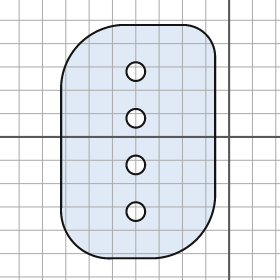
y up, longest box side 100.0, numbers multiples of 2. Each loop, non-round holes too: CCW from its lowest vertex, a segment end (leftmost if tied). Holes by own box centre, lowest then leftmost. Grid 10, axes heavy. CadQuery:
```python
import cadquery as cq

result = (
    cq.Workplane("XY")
    .moveTo(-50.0, -52.0)
    .lineTo(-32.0, -52.0)
    .threePointArc((-14.0, -44.0), (-6.0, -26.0))
    .lineTo(-6.0, 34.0)
    .threePointArc((-10.0, 44.0), (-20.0, 48.0))
    .lineTo(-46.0, 48.0)
    .threePointArc((-64.0, 40.0), (-72.0, 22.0))
    .lineTo(-72.0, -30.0)
    .threePointArc((-66.0, -46.0), (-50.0, -52.0))
    .close()
    .moveTo(-40.0, -32.0)
    .circle(4.0)
    .moveTo(-40.0, -12.0)
    .circle(4.0)
    .moveTo(-40.0, 8.0)
    .circle(4.0)
    .moveTo(-40.0, 28.0)
    .circle(4.0)
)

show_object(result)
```